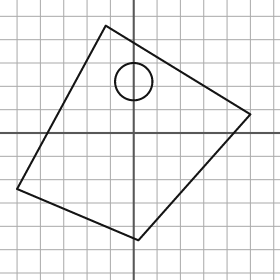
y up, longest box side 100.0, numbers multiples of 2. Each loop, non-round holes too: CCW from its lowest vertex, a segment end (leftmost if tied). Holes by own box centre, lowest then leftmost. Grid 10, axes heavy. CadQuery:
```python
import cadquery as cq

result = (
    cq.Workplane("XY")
    .moveTo(2.0, -46.0)
    .lineTo(50.0, 8.0)
    .lineTo(-12.0, 46.0)
    .lineTo(-50.0, -24.0)
    .close()
    .moveTo(0.0, 22.0)
    .circle(8.0)
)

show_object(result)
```